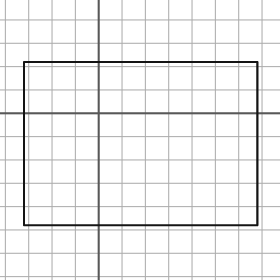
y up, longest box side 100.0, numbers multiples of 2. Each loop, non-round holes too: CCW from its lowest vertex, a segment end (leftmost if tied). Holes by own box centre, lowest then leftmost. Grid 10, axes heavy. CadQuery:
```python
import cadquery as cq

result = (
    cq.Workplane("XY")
    .moveTo(-32.0, -48.0)
    .lineTo(68.0, -48.0)
    .lineTo(68.0, 22.0)
    .lineTo(-32.0, 22.0)
    .close()
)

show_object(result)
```